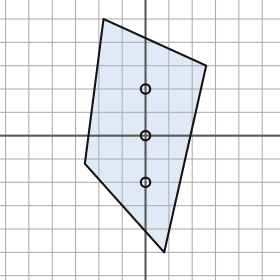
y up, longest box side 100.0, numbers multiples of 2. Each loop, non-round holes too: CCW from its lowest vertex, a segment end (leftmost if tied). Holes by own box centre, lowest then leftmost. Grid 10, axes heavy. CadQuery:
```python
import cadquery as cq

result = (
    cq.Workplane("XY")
    .moveTo(8.0, -50.0)
    .lineTo(26.0, 30.0)
    .lineTo(-18.0, 50.0)
    .lineTo(-26.0, -12.0)
    .close()
    .moveTo(0.0, -20.0)
    .circle(2.0)
    .moveTo(0.0, 0.0)
    .circle(2.0)
    .moveTo(0.0, 20.0)
    .circle(2.0)
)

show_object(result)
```